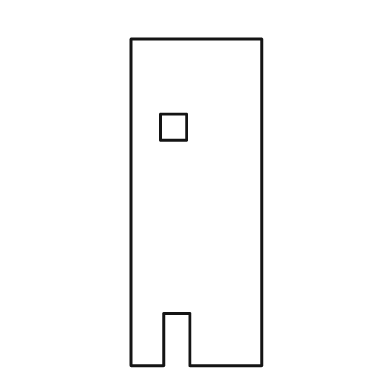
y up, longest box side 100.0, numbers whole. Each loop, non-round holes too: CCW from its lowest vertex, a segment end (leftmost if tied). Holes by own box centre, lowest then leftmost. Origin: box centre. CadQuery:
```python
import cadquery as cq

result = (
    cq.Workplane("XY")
    .moveTo(-20.0, -50.0)
    .lineTo(-10.0, -50.0)
    .lineTo(-10.0, -34.0)
    .lineTo(-2.0, -34.0)
    .lineTo(-2.0, -50.0)
    .lineTo(20.0, -50.0)
    .lineTo(20.0, 50.0)
    .lineTo(-20.0, 50.0)
    .close()
    .moveTo(-11.0, 19.0)
    .lineTo(-3.0, 19.0)
    .lineTo(-3.0, 27.0)
    .lineTo(-11.0, 27.0)
    .close()
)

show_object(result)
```